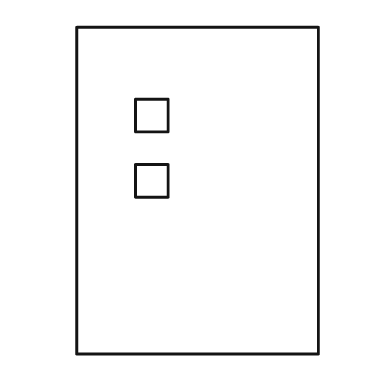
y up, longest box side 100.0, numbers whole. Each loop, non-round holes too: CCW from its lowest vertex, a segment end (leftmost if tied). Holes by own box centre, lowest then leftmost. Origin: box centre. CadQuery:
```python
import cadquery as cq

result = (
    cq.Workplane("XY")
    .moveTo(-37.0, -50.0)
    .lineTo(37.0, -50.0)
    .lineTo(37.0, 50.0)
    .lineTo(-37.0, 50.0)
    .close()
    .moveTo(-19.0, -2.0)
    .lineTo(-9.0, -2.0)
    .lineTo(-9.0, 8.0)
    .lineTo(-19.0, 8.0)
    .close()
    .moveTo(-19.0, 18.0)
    .lineTo(-9.0, 18.0)
    .lineTo(-9.0, 28.0)
    .lineTo(-19.0, 28.0)
    .close()
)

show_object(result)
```